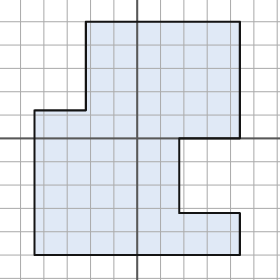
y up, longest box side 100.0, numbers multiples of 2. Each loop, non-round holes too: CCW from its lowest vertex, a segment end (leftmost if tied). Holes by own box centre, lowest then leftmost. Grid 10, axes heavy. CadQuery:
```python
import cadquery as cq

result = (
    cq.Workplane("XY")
    .moveTo(-44.0, -50.0)
    .lineTo(44.0, -50.0)
    .lineTo(44.0, -32.0)
    .lineTo(18.0, -32.0)
    .lineTo(18.0, 0.0)
    .lineTo(44.0, 0.0)
    .lineTo(44.0, 50.0)
    .lineTo(-22.0, 50.0)
    .lineTo(-22.0, 12.0)
    .lineTo(-44.0, 12.0)
    .close()
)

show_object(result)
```